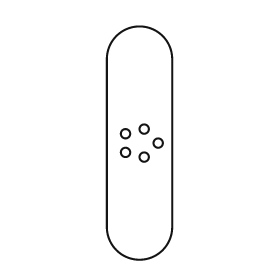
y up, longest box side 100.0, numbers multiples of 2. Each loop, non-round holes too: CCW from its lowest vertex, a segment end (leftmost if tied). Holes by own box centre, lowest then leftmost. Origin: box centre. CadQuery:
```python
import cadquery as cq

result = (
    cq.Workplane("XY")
    .moveTo(-14.0, -36.0)
    .threePointArc((0.0, -50.0), (14.0, -36.0))
    .lineTo(14.0, 36.0)
    .threePointArc((0.0, 50.0), (-14.0, 36.0))
    .close()
    .moveTo(2.0, -6.0)
    .circle(2.0)
    .moveTo(-6.0, -4.0)
    .circle(2.0)
    .moveTo(8.0, 0.0)
    .circle(2.0)
    .moveTo(-6.0, 4.0)
    .circle(2.0)
    .moveTo(2.0, 6.0)
    .circle(2.0)
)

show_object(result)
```